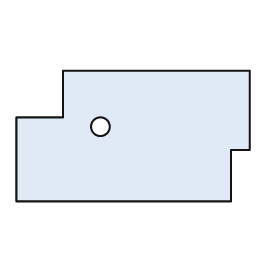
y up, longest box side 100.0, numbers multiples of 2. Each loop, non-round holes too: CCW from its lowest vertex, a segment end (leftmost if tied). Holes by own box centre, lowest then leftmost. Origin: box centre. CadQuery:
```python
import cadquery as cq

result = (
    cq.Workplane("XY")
    .moveTo(-50.0, -28.0)
    .lineTo(42.0, -28.0)
    .lineTo(42.0, -6.0)
    .lineTo(50.0, -6.0)
    .lineTo(50.0, 28.0)
    .lineTo(-30.0, 28.0)
    .lineTo(-30.0, 8.0)
    .lineTo(-50.0, 8.0)
    .close()
    .moveTo(-14.0, 4.0)
    .circle(4.0)
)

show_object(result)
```